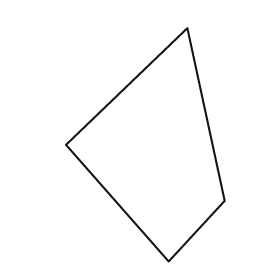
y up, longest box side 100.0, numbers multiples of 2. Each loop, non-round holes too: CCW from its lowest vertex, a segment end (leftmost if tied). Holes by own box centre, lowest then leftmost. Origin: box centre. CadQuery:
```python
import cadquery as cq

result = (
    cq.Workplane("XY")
    .moveTo(10.0, -50.0)
    .lineTo(34.0, -24.0)
    .lineTo(18.0, 50.0)
    .lineTo(-34.0, 0.0)
    .close()
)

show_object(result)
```